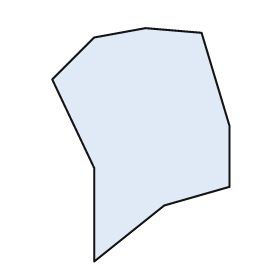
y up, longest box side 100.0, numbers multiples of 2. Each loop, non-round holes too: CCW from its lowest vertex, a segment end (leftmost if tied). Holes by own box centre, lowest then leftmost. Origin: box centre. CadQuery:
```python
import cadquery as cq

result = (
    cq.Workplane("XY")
    .moveTo(-20.0, -50.0)
    .lineTo(10.0, -26.0)
    .lineTo(38.0, -18.0)
    .lineTo(38.0, 8.0)
    .lineTo(26.0, 48.0)
    .lineTo(2.0, 50.0)
    .lineTo(-20.0, 46.0)
    .lineTo(-38.0, 28.0)
    .lineTo(-20.0, -10.0)
    .close()
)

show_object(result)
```